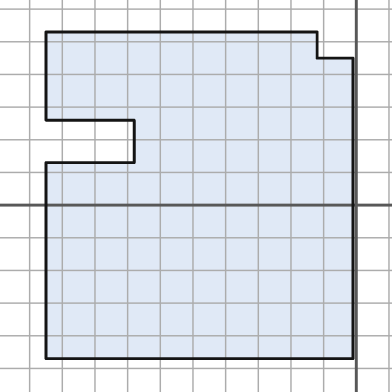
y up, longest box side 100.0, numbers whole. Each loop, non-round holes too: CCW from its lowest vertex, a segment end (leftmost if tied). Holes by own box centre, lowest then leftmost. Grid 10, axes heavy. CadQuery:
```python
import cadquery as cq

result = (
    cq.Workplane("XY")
    .moveTo(-95.0, -47.0)
    .lineTo(-1.0, -47.0)
    .lineTo(-1.0, 45.0)
    .lineTo(-12.0, 45.0)
    .lineTo(-12.0, 53.0)
    .lineTo(-95.0, 53.0)
    .lineTo(-95.0, 26.0)
    .lineTo(-68.0, 26.0)
    .lineTo(-68.0, 13.0)
    .lineTo(-95.0, 13.0)
    .close()
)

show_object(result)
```